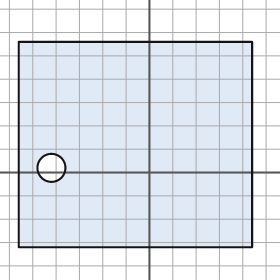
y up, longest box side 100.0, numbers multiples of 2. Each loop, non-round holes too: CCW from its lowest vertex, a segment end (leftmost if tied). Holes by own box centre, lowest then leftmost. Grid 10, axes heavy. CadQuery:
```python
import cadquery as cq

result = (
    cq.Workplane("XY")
    .moveTo(-56.0, -32.0)
    .lineTo(44.0, -32.0)
    .lineTo(44.0, 56.0)
    .lineTo(-56.0, 56.0)
    .close()
    .moveTo(-42.0, 2.0)
    .circle(6.0)
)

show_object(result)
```